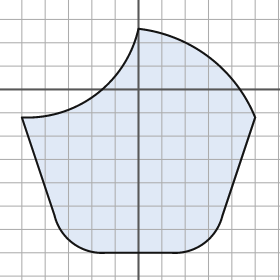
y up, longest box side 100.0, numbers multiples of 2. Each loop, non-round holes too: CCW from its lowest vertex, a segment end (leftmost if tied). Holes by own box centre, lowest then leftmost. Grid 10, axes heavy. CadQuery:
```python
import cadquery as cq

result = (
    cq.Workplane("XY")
    .moveTo(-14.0, -70.0)
    .lineTo(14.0, -70.0)
    .threePointArc((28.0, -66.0), (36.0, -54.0))
    .lineTo(50.0, -12.0)
    .threePointArc((30.0, 14.0), (0.0, 26.0))
    .threePointArc((-18.0, -2.0), (-50.0, -12.0))
    .lineTo(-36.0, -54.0)
    .threePointArc((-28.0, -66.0), (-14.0, -70.0))
    .close()
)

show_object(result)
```